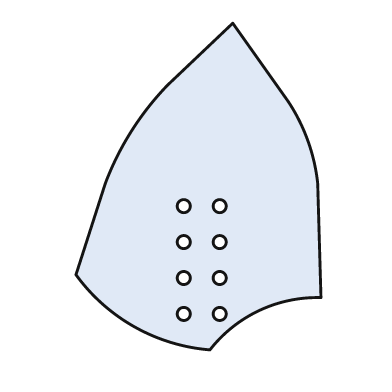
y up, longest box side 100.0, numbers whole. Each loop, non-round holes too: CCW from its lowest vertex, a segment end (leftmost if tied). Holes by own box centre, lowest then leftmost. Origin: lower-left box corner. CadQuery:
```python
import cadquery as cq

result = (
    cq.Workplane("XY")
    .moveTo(41.0, 0.0)
    .threePointArc((56.0, 12.0), (75.0, 16.0))
    .lineTo(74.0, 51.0)
    .threePointArc((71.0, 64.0), (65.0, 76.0))
    .lineTo(48.0, 100.0)
    .lineTo(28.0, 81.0)
    .threePointArc((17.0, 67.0), (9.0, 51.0))
    .lineTo(0.0, 23.0)
    .threePointArc((18.0, 7.0), (41.0, 0.0))
    .close()
    .moveTo(33.0, 11.0)
    .circle(2.0)
    .moveTo(44.0, 11.0)
    .circle(2.0)
    .moveTo(33.0, 22.0)
    .circle(2.0)
    .moveTo(44.0, 22.0)
    .circle(2.0)
    .moveTo(33.0, 33.0)
    .circle(2.0)
    .moveTo(44.0, 33.0)
    .circle(2.0)
    .moveTo(33.0, 44.0)
    .circle(2.0)
    .moveTo(44.0, 44.0)
    .circle(2.0)
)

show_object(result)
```